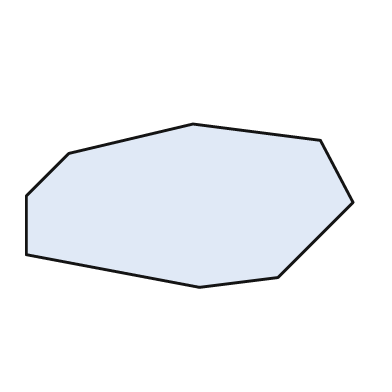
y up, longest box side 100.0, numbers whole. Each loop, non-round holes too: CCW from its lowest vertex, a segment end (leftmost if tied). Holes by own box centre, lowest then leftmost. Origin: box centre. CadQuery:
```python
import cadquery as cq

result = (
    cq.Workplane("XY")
    .moveTo(3.0, -25.0)
    .lineTo(27.0, -22.0)
    .lineTo(50.0, 1.0)
    .lineTo(40.0, 20.0)
    .lineTo(1.0, 25.0)
    .lineTo(-37.0, 16.0)
    .lineTo(-50.0, 3.0)
    .lineTo(-50.0, -15.0)
    .close()
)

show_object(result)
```